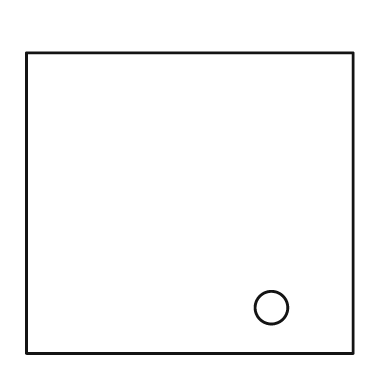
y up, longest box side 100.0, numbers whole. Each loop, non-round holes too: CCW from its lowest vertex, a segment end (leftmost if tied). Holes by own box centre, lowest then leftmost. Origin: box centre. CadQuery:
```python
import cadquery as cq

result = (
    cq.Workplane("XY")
    .moveTo(-50.0, -46.0)
    .lineTo(50.0, -46.0)
    .lineTo(50.0, 46.0)
    .lineTo(-50.0, 46.0)
    .close()
    .moveTo(25.0, -32.0)
    .circle(5.0)
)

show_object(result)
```